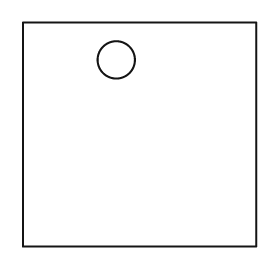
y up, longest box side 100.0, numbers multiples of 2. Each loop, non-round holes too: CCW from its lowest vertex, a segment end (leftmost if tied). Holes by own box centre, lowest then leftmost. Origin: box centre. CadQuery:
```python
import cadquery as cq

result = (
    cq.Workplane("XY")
    .moveTo(-50.0, -48.0)
    .lineTo(50.0, -48.0)
    .lineTo(50.0, 48.0)
    .lineTo(-50.0, 48.0)
    .close()
    .moveTo(-10.0, 32.0)
    .circle(8.0)
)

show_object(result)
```